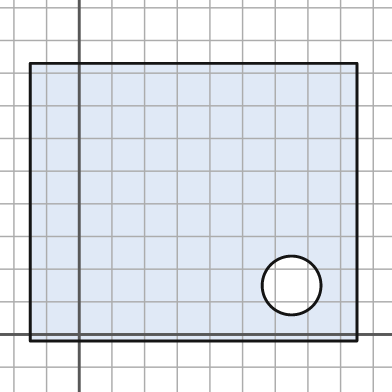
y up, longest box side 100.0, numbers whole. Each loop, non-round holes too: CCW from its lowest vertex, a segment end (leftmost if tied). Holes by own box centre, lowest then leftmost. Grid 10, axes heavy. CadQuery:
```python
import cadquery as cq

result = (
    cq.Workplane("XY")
    .moveTo(-15.0, -2.0)
    .lineTo(85.0, -2.0)
    .lineTo(85.0, 83.0)
    .lineTo(-15.0, 83.0)
    .close()
    .moveTo(65.0, 15.0)
    .circle(9.0)
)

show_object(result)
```